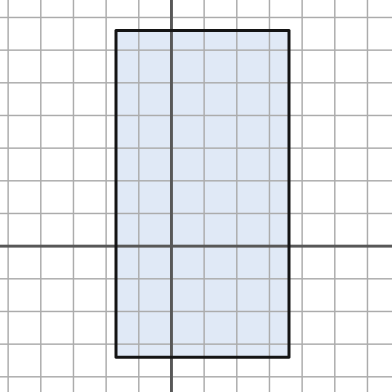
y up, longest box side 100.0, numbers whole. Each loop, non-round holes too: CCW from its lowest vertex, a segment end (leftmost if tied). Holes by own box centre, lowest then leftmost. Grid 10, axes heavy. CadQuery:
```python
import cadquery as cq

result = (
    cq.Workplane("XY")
    .moveTo(-17.0, -34.0)
    .lineTo(36.0, -34.0)
    .lineTo(36.0, 66.0)
    .lineTo(-17.0, 66.0)
    .close()
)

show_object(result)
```